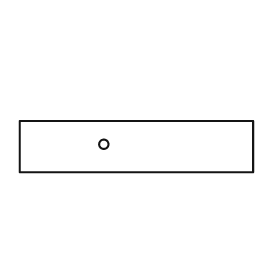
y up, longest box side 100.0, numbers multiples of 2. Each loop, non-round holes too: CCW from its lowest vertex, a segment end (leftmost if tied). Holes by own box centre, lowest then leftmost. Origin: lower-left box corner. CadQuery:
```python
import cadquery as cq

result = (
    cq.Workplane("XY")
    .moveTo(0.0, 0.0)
    .lineTo(100.0, 0.0)
    .lineTo(100.0, 22.0)
    .lineTo(0.0, 22.0)
    .close()
    .moveTo(36.0, 12.0)
    .circle(2.0)
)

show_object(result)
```